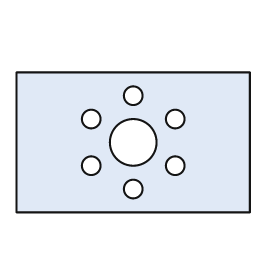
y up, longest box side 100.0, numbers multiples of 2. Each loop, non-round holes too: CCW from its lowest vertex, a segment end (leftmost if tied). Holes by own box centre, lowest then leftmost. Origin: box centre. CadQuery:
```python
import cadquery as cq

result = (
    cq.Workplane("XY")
    .moveTo(-50.0, -30.0)
    .lineTo(50.0, -30.0)
    .lineTo(50.0, 30.0)
    .lineTo(-50.0, 30.0)
    .close()
    .moveTo(0.0, -20.0)
    .circle(4.0)
    .moveTo(-18.0, -10.0)
    .circle(4.0)
    .moveTo(18.0, -10.0)
    .circle(4.0)
    .moveTo(0.0, 0.0)
    .circle(10.0)
    .moveTo(-18.0, 10.0)
    .circle(4.0)
    .moveTo(18.0, 10.0)
    .circle(4.0)
    .moveTo(0.0, 20.0)
    .circle(4.0)
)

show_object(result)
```